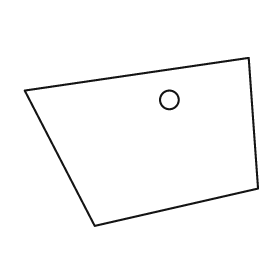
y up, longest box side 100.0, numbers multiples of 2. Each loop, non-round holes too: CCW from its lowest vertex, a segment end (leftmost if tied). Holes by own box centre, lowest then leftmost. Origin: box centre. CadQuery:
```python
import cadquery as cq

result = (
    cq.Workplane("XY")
    .moveTo(-20.0, -36.0)
    .lineTo(50.0, -20.0)
    .lineTo(46.0, 36.0)
    .lineTo(-50.0, 22.0)
    .close()
    .moveTo(12.0, 18.0)
    .circle(4.0)
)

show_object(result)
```